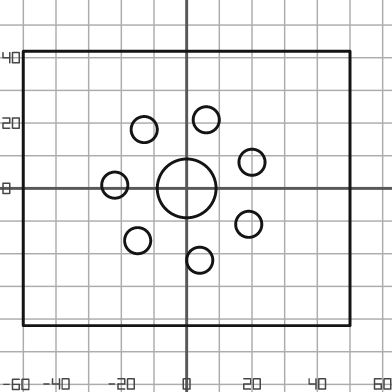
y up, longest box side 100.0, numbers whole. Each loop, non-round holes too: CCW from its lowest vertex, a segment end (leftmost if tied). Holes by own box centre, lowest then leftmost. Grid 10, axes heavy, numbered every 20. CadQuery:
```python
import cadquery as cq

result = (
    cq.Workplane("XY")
    .moveTo(-50.0, -42.0)
    .lineTo(50.0, -42.0)
    .lineTo(50.0, 42.0)
    .lineTo(-50.0, 42.0)
    .close()
    .moveTo(4.0, -22.0)
    .circle(4.0)
    .moveTo(-15.0, -16.0)
    .circle(4.0)
    .moveTo(19.0, -11.0)
    .circle(4.0)
    .moveTo(0.0, 0.0)
    .circle(9.0)
    .moveTo(-22.0, 1.0)
    .circle(4.0)
    .moveTo(20.0, 8.0)
    .circle(4.0)
    .moveTo(-13.0, 18.0)
    .circle(4.0)
    .moveTo(6.0, 21.0)
    .circle(4.0)
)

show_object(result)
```